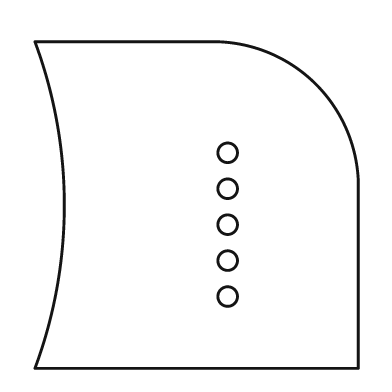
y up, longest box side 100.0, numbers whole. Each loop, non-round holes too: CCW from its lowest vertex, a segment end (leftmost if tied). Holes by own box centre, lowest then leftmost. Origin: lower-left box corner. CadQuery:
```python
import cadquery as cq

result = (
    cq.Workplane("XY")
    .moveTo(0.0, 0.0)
    .lineTo(99.0, 0.0)
    .lineTo(99.0, 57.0)
    .threePointArc((86.0, 87.0), (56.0, 100.0))
    .lineTo(0.0, 100.0)
    .threePointArc((9.0, 50.0), (0.0, 0.0))
    .close()
    .moveTo(59.0, 22.0)
    .circle(3.0)
    .moveTo(59.0, 33.0)
    .circle(3.0)
    .moveTo(59.0, 44.0)
    .circle(3.0)
    .moveTo(59.0, 55.0)
    .circle(3.0)
    .moveTo(59.0, 66.0)
    .circle(3.0)
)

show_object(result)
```